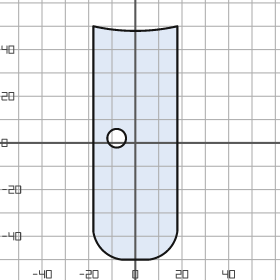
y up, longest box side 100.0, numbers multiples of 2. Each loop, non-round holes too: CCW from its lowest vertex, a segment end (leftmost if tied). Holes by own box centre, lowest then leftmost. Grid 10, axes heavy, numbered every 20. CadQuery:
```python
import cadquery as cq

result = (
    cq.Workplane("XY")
    .moveTo(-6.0, -50.0)
    .lineTo(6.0, -50.0)
    .threePointArc((14.0, -46.0), (18.0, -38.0))
    .lineTo(18.0, 50.0)
    .threePointArc((0.0, 48.0), (-18.0, 50.0))
    .lineTo(-18.0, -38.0)
    .threePointArc((-14.0, -46.0), (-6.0, -50.0))
    .close()
    .moveTo(-8.0, 2.0)
    .circle(4.0)
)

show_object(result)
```